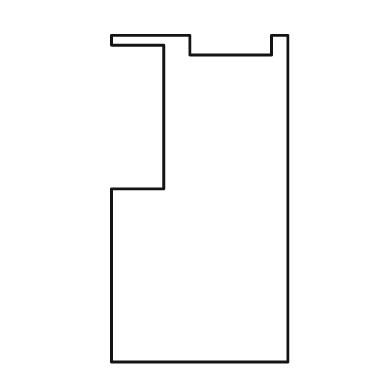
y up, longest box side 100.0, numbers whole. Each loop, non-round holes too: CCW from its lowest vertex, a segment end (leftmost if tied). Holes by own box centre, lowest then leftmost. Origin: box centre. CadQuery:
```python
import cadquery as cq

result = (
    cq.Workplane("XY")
    .moveTo(-27.0, -50.0)
    .lineTo(27.0, -50.0)
    .lineTo(27.0, 50.0)
    .lineTo(22.0, 50.0)
    .lineTo(22.0, 44.0)
    .lineTo(-3.0, 44.0)
    .lineTo(-3.0, 50.0)
    .lineTo(-27.0, 50.0)
    .lineTo(-27.0, 47.0)
    .lineTo(-11.0, 47.0)
    .lineTo(-11.0, 3.0)
    .lineTo(-27.0, 3.0)
    .close()
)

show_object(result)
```